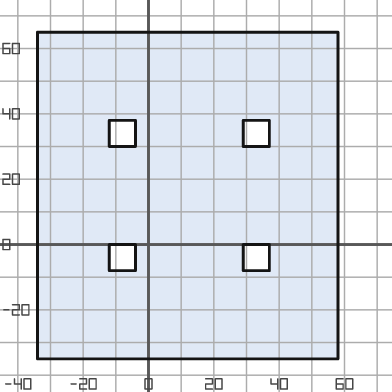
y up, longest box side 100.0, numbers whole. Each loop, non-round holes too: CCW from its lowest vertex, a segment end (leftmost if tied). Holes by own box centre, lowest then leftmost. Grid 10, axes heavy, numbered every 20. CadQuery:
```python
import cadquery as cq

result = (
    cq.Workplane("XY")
    .moveTo(-34.0, -35.0)
    .lineTo(58.0, -35.0)
    .lineTo(58.0, 65.0)
    .lineTo(-34.0, 65.0)
    .close()
    .moveTo(-12.0, -8.0)
    .lineTo(-4.0, -8.0)
    .lineTo(-4.0, 0.0)
    .lineTo(-12.0, 0.0)
    .close()
    .moveTo(29.0, -8.0)
    .lineTo(37.0, -8.0)
    .lineTo(37.0, 0.0)
    .lineTo(29.0, 0.0)
    .close()
    .moveTo(-12.0, 30.0)
    .lineTo(-4.0, 30.0)
    .lineTo(-4.0, 38.0)
    .lineTo(-12.0, 38.0)
    .close()
    .moveTo(29.0, 30.0)
    .lineTo(37.0, 30.0)
    .lineTo(37.0, 38.0)
    .lineTo(29.0, 38.0)
    .close()
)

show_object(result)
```